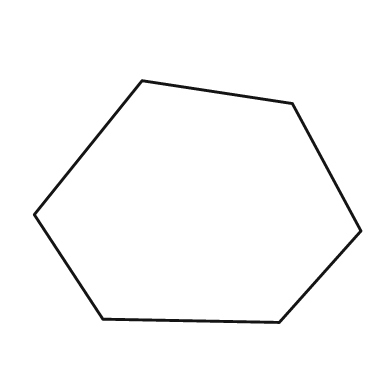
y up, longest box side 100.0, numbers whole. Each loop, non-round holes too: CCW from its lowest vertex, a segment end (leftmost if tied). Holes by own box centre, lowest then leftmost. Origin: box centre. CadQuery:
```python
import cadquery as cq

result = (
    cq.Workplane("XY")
    .moveTo(25.0, -37.0)
    .lineTo(50.0, -9.0)
    .lineTo(29.0, 30.0)
    .lineTo(-17.0, 37.0)
    .lineTo(-50.0, -4.0)
    .lineTo(-29.0, -36.0)
    .close()
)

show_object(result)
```